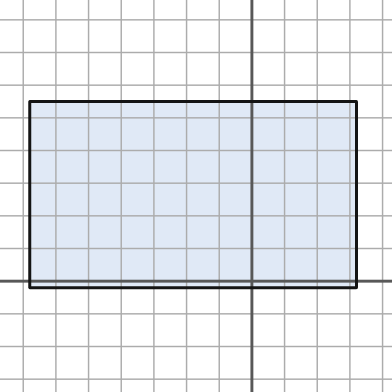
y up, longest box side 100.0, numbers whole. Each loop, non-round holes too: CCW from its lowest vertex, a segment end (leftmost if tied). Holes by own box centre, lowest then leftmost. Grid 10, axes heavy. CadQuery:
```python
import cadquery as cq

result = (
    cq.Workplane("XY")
    .moveTo(-68.0, -2.0)
    .lineTo(32.0, -2.0)
    .lineTo(32.0, 55.0)
    .lineTo(-68.0, 55.0)
    .close()
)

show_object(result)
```